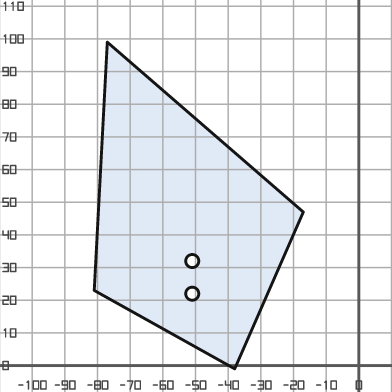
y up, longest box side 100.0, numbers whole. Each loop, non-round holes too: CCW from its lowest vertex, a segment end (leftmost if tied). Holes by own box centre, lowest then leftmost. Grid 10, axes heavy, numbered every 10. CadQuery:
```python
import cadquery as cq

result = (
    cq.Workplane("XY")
    .moveTo(-38.0, -1.0)
    .lineTo(-17.0, 47.0)
    .lineTo(-77.0, 99.0)
    .lineTo(-81.0, 23.0)
    .close()
    .moveTo(-51.0, 22.0)
    .circle(2.0)
    .moveTo(-51.0, 32.0)
    .circle(2.0)
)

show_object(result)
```